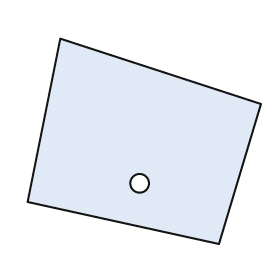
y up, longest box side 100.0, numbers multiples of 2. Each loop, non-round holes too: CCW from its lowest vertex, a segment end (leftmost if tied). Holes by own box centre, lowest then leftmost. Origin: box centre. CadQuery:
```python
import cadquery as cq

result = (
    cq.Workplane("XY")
    .moveTo(32.0, -44.0)
    .lineTo(50.0, 16.0)
    .lineTo(-36.0, 44.0)
    .lineTo(-50.0, -26.0)
    .close()
    .moveTo(-2.0, -18.0)
    .circle(4.0)
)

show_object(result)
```